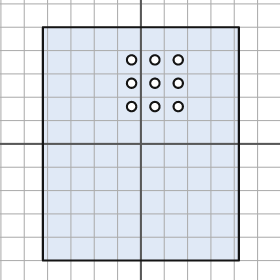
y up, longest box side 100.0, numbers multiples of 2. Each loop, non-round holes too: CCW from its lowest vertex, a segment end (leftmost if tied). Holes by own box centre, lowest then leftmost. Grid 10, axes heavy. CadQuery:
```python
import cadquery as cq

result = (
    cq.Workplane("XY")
    .moveTo(-42.0, -50.0)
    .lineTo(42.0, -50.0)
    .lineTo(42.0, 50.0)
    .lineTo(-42.0, 50.0)
    .close()
    .moveTo(-4.0, 16.0)
    .circle(2.0)
    .moveTo(6.0, 16.0)
    .circle(2.0)
    .moveTo(16.0, 16.0)
    .circle(2.0)
    .moveTo(-4.0, 26.0)
    .circle(2.0)
    .moveTo(6.0, 26.0)
    .circle(2.0)
    .moveTo(16.0, 26.0)
    .circle(2.0)
    .moveTo(-4.0, 36.0)
    .circle(2.0)
    .moveTo(6.0, 36.0)
    .circle(2.0)
    .moveTo(16.0, 36.0)
    .circle(2.0)
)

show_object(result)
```